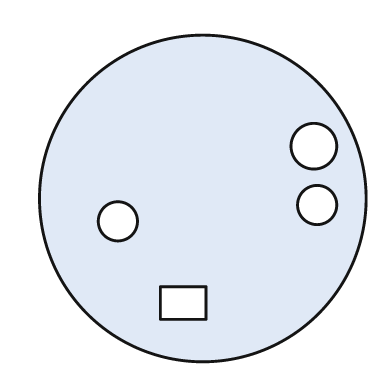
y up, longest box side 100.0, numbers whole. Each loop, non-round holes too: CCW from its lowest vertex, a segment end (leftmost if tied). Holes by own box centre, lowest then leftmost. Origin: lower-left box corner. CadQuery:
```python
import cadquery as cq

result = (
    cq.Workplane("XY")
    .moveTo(50.0, 50.0)
    .circle(50.0)
    .moveTo(37.0, 13.0)
    .lineTo(51.0, 13.0)
    .lineTo(51.0, 23.0)
    .lineTo(37.0, 23.0)
    .close()
    .moveTo(24.0, 43.0)
    .circle(6.0)
    .moveTo(85.0, 48.0)
    .circle(6.0)
    .moveTo(84.0, 66.0)
    .circle(7.0)
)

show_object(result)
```